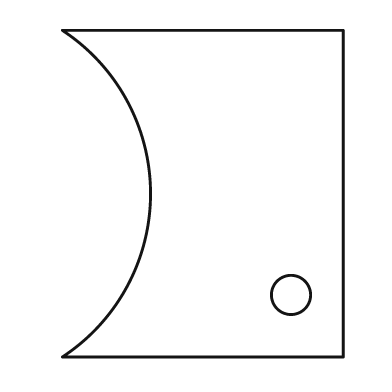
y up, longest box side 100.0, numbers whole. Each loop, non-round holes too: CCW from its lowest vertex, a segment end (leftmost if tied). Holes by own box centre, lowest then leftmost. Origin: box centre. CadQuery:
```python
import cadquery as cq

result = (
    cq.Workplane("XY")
    .moveTo(-43.0, -50.0)
    .lineTo(43.0, -50.0)
    .lineTo(43.0, 50.0)
    .lineTo(-43.0, 50.0)
    .threePointArc((-16.0, 0.0), (-43.0, -50.0))
    .close()
    .moveTo(27.0, -31.0)
    .circle(6.0)
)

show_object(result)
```